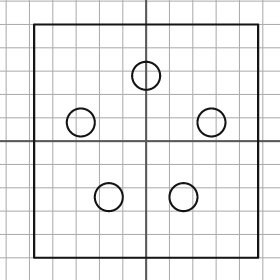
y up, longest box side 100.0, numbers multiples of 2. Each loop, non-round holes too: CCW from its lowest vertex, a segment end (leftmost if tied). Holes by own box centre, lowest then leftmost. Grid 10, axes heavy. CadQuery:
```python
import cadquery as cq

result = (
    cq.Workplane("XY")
    .moveTo(-48.0, -50.0)
    .lineTo(48.0, -50.0)
    .lineTo(48.0, 50.0)
    .lineTo(-48.0, 50.0)
    .close()
    .moveTo(-16.0, -24.0)
    .circle(6.0)
    .moveTo(16.0, -24.0)
    .circle(6.0)
    .moveTo(-28.0, 8.0)
    .circle(6.0)
    .moveTo(28.0, 8.0)
    .circle(6.0)
    .moveTo(0.0, 28.0)
    .circle(6.0)
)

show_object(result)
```